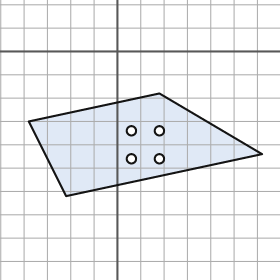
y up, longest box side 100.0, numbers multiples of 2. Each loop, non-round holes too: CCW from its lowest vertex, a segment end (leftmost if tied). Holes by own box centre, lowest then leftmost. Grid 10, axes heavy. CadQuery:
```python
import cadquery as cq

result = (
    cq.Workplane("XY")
    .moveTo(-22.0, -62.0)
    .lineTo(62.0, -44.0)
    .lineTo(18.0, -18.0)
    .lineTo(-38.0, -30.0)
    .close()
    .moveTo(6.0, -46.0)
    .circle(2.0)
    .moveTo(18.0, -46.0)
    .circle(2.0)
    .moveTo(6.0, -34.0)
    .circle(2.0)
    .moveTo(18.0, -34.0)
    .circle(2.0)
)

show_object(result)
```